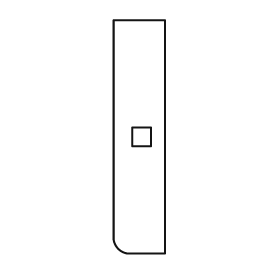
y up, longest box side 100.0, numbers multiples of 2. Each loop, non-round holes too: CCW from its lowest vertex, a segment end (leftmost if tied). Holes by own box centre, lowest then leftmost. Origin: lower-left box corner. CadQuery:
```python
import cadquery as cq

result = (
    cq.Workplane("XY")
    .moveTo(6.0, 0.0)
    .lineTo(22.0, 0.0)
    .lineTo(22.0, 100.0)
    .lineTo(0.0, 100.0)
    .lineTo(0.0, 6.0)
    .threePointArc((2.0, 2.0), (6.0, 0.0))
    .close()
    .moveTo(8.0, 46.0)
    .lineTo(16.0, 46.0)
    .lineTo(16.0, 54.0)
    .lineTo(8.0, 54.0)
    .close()
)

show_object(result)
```